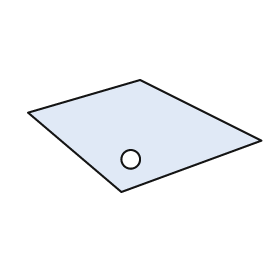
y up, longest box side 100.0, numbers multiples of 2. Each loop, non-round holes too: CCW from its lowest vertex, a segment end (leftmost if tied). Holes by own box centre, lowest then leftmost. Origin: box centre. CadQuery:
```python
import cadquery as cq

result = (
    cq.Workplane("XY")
    .moveTo(-10.0, -24.0)
    .lineTo(50.0, -2.0)
    .lineTo(-2.0, 24.0)
    .lineTo(-50.0, 10.0)
    .close()
    .moveTo(-6.0, -10.0)
    .circle(4.0)
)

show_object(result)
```